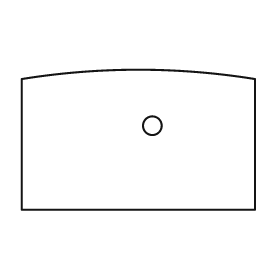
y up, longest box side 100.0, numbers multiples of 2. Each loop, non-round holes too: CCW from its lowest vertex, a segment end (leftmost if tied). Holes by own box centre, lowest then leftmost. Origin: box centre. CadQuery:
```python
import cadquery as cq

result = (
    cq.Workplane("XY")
    .moveTo(-50.0, -30.0)
    .lineTo(50.0, -30.0)
    .lineTo(50.0, 26.0)
    .threePointArc((0.0, 30.0), (-50.0, 26.0))
    .close()
    .moveTo(6.0, 6.0)
    .circle(4.0)
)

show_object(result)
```